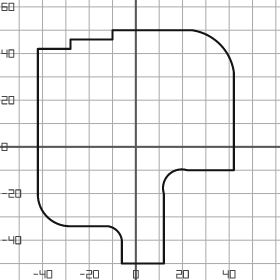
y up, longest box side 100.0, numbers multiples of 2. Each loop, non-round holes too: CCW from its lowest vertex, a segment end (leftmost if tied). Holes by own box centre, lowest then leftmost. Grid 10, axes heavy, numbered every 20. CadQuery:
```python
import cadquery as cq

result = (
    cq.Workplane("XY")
    .moveTo(-6.0, -50.0)
    .lineTo(12.0, -50.0)
    .lineTo(12.0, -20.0)
    .threePointArc((14.0, -12.0), (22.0, -10.0))
    .lineTo(42.0, -10.0)
    .lineTo(42.0, 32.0)
    .threePointArc((36.0, 44.0), (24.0, 50.0))
    .lineTo(-10.0, 50.0)
    .lineTo(-10.0, 46.0)
    .lineTo(-28.0, 46.0)
    .lineTo(-28.0, 42.0)
    .lineTo(-42.0, 42.0)
    .lineTo(-42.0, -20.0)
    .threePointArc((-38.0, -30.0), (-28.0, -34.0))
    .lineTo(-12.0, -34.0)
    .threePointArc((-8.0, -36.0), (-6.0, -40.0))
    .close()
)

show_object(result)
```